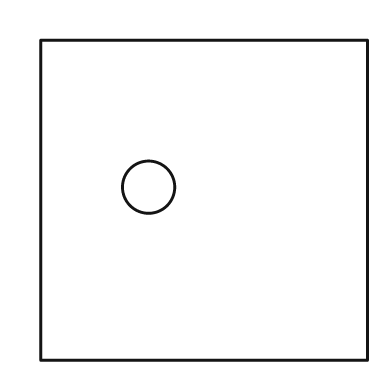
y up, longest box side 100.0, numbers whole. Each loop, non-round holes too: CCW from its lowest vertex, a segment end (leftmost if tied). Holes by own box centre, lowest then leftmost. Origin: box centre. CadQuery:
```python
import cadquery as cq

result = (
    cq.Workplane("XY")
    .moveTo(-50.0, -49.0)
    .lineTo(50.0, -49.0)
    .lineTo(50.0, 49.0)
    .lineTo(-50.0, 49.0)
    .close()
    .moveTo(-17.0, 4.0)
    .circle(8.0)
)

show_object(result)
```